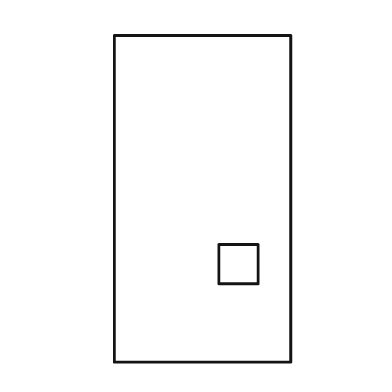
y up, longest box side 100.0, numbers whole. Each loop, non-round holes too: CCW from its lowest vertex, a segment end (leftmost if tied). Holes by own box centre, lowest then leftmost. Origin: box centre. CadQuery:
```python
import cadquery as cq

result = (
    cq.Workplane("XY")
    .moveTo(-27.0, -50.0)
    .lineTo(27.0, -50.0)
    .lineTo(27.0, 50.0)
    .lineTo(-27.0, 50.0)
    .close()
    .moveTo(5.0, -26.0)
    .lineTo(17.0, -26.0)
    .lineTo(17.0, -14.0)
    .lineTo(5.0, -14.0)
    .close()
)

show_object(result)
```